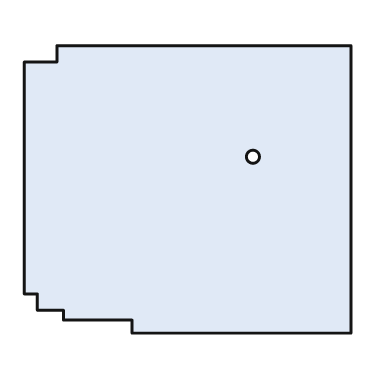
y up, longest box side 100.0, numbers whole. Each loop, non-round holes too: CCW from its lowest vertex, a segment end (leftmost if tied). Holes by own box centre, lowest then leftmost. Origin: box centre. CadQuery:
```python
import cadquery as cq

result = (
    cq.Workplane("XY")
    .moveTo(-17.0, -44.0)
    .lineTo(50.0, -44.0)
    .lineTo(50.0, 44.0)
    .lineTo(-40.0, 44.0)
    .lineTo(-40.0, 39.0)
    .lineTo(-50.0, 39.0)
    .lineTo(-50.0, -32.0)
    .lineTo(-46.0, -32.0)
    .lineTo(-46.0, -37.0)
    .lineTo(-38.0, -37.0)
    .lineTo(-38.0, -40.0)
    .lineTo(-17.0, -40.0)
    .close()
    .moveTo(20.0, 10.0)
    .circle(2.0)
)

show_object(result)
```